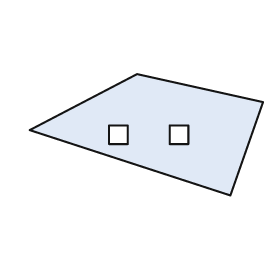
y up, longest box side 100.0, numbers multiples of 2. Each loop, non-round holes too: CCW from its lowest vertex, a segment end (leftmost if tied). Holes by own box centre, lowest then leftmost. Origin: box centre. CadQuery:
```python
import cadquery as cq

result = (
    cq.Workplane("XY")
    .moveTo(36.0, -26.0)
    .lineTo(50.0, 14.0)
    .lineTo(-4.0, 26.0)
    .lineTo(-50.0, 2.0)
    .close()
    .moveTo(-16.0, -4.0)
    .lineTo(-8.0, -4.0)
    .lineTo(-8.0, 4.0)
    .lineTo(-16.0, 4.0)
    .close()
    .moveTo(10.0, -4.0)
    .lineTo(18.0, -4.0)
    .lineTo(18.0, 4.0)
    .lineTo(10.0, 4.0)
    .close()
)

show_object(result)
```